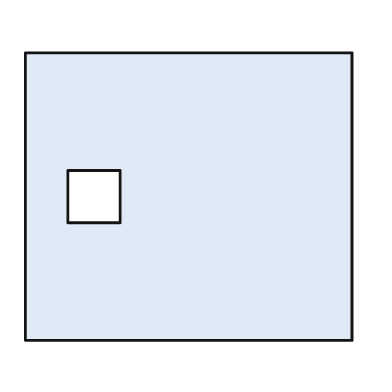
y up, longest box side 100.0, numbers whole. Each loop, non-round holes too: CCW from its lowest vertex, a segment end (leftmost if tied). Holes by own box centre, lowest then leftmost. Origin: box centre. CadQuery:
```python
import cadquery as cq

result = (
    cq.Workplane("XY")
    .moveTo(-50.0, -44.0)
    .lineTo(50.0, -44.0)
    .lineTo(50.0, 44.0)
    .lineTo(-50.0, 44.0)
    .close()
    .moveTo(-37.0, -8.0)
    .lineTo(-21.0, -8.0)
    .lineTo(-21.0, 8.0)
    .lineTo(-37.0, 8.0)
    .close()
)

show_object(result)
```